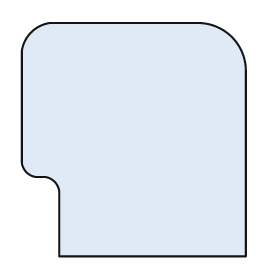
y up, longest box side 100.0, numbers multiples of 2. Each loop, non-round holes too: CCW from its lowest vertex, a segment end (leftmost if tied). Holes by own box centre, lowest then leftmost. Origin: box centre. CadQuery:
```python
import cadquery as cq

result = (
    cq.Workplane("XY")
    .moveTo(-32.0, -50.0)
    .lineTo(48.0, -50.0)
    .lineTo(48.0, 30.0)
    .threePointArc((42.0, 44.0), (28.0, 50.0))
    .lineTo(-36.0, 50.0)
    .threePointArc((-44.0, 46.0), (-48.0, 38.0))
    .lineTo(-48.0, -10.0)
    .threePointArc((-46.0, -14.0), (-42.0, -16.0))
    .lineTo(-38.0, -16.0)
    .threePointArc((-34.0, -18.0), (-32.0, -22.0))
    .close()
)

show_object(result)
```